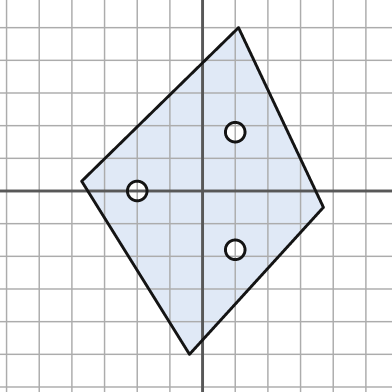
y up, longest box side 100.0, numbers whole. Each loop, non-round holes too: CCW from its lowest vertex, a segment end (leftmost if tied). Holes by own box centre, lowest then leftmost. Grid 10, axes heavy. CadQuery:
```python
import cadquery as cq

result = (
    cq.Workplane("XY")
    .moveTo(-4.0, -50.0)
    .lineTo(37.0, -5.0)
    .lineTo(11.0, 50.0)
    .lineTo(-37.0, 3.0)
    .close()
    .moveTo(10.0, -18.0)
    .circle(3.0)
    .moveTo(-20.0, 0.0)
    .circle(3.0)
    .moveTo(10.0, 18.0)
    .circle(3.0)
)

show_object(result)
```